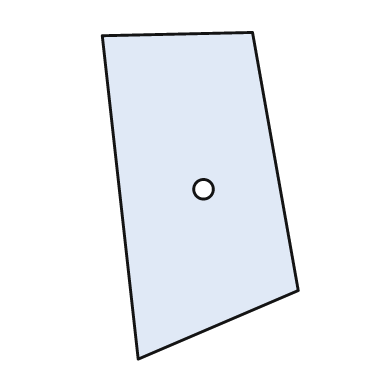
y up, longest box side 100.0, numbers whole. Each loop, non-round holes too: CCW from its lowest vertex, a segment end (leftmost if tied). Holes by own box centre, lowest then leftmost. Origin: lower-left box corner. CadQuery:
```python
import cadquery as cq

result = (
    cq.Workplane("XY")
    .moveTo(11.0, 0.0)
    .lineTo(60.0, 21.0)
    .lineTo(46.0, 100.0)
    .lineTo(0.0, 99.0)
    .close()
    .moveTo(31.0, 52.0)
    .circle(3.0)
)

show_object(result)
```